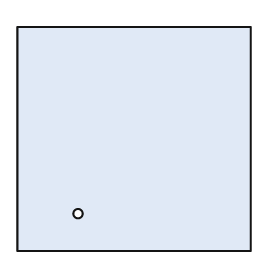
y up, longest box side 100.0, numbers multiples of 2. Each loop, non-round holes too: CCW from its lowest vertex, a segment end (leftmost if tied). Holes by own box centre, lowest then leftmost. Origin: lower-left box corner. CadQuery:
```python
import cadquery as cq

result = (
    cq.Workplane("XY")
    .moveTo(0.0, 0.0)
    .lineTo(100.0, 0.0)
    .lineTo(100.0, 96.0)
    .lineTo(0.0, 96.0)
    .close()
    .moveTo(26.0, 16.0)
    .circle(2.0)
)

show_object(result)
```